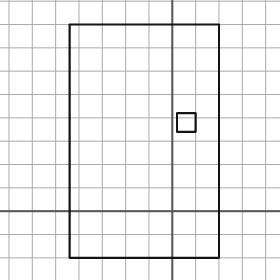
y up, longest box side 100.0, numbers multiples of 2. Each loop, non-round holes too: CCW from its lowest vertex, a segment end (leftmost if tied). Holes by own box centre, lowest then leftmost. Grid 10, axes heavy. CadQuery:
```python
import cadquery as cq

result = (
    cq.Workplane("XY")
    .moveTo(-44.0, -20.0)
    .lineTo(20.0, -20.0)
    .lineTo(20.0, 80.0)
    .lineTo(-44.0, 80.0)
    .close()
    .moveTo(2.0, 34.0)
    .lineTo(10.0, 34.0)
    .lineTo(10.0, 42.0)
    .lineTo(2.0, 42.0)
    .close()
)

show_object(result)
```